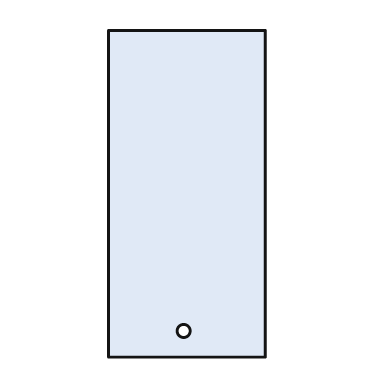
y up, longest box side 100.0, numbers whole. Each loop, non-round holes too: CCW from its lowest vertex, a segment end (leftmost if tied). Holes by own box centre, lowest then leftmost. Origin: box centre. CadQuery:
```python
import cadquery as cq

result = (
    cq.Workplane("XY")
    .moveTo(-24.0, -50.0)
    .lineTo(24.0, -50.0)
    .lineTo(24.0, 50.0)
    .lineTo(-24.0, 50.0)
    .close()
    .moveTo(-1.0, -42.0)
    .circle(2.0)
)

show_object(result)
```